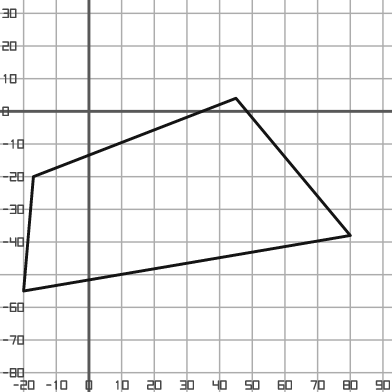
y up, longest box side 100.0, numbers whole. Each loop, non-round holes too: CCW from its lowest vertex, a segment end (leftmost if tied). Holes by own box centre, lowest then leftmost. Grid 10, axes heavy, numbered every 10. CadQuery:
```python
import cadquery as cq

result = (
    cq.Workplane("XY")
    .moveTo(-20.0, -55.0)
    .lineTo(80.0, -38.0)
    .lineTo(45.0, 4.0)
    .lineTo(-17.0, -20.0)
    .close()
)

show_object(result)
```